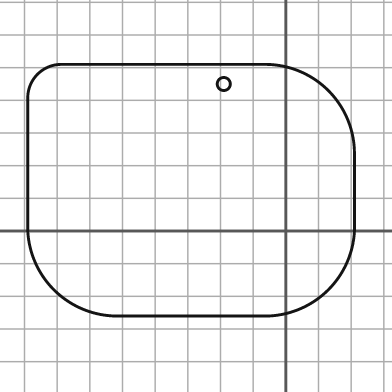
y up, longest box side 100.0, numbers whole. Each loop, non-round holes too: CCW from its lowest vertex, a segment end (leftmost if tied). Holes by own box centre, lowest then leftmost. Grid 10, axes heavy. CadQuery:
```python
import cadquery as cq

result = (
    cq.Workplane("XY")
    .moveTo(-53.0, -26.0)
    .lineTo(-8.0, -26.0)
    .threePointArc((13.0, -18.0), (21.0, 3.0))
    .lineTo(21.0, 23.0)
    .threePointArc((13.0, 43.0), (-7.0, 51.0))
    .lineTo(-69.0, 51.0)
    .threePointArc((-76.0, 48.0), (-79.0, 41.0))
    .lineTo(-79.0, 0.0)
    .threePointArc((-71.0, -18.0), (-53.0, -26.0))
    .close()
    .moveTo(-19.0, 45.0)
    .circle(2.0)
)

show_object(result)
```